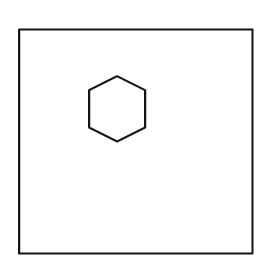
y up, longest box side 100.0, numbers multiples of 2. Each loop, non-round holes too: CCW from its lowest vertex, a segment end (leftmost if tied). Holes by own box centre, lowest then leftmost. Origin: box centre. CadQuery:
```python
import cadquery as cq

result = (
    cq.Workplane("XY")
    .moveTo(-50.0, -48.0)
    .lineTo(50.0, -48.0)
    .lineTo(50.0, 48.0)
    .lineTo(-50.0, 48.0)
    .close()
    .moveTo(-8.0, 0.0)
    .lineTo(4.0, 6.0)
    .lineTo(4.0, 22.0)
    .lineTo(-8.0, 28.0)
    .lineTo(-20.0, 22.0)
    .lineTo(-20.0, 6.0)
    .close()
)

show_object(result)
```